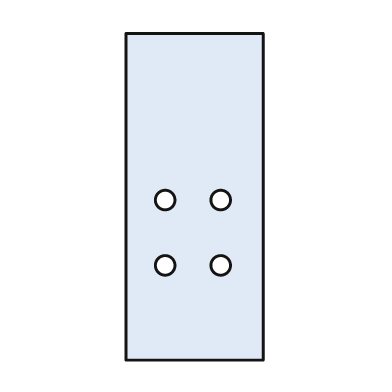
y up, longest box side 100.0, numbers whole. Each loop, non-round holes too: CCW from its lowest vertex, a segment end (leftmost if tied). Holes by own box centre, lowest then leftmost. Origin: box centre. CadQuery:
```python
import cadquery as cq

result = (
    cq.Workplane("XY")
    .moveTo(-21.0, -50.0)
    .lineTo(21.0, -50.0)
    .lineTo(21.0, 50.0)
    .lineTo(-21.0, 50.0)
    .close()
    .moveTo(-9.0, -21.0)
    .circle(3.0)
    .moveTo(8.0, -21.0)
    .circle(3.0)
    .moveTo(-9.0, -1.0)
    .circle(3.0)
    .moveTo(8.0, -1.0)
    .circle(3.0)
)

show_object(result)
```